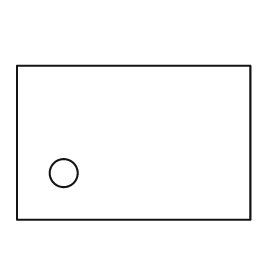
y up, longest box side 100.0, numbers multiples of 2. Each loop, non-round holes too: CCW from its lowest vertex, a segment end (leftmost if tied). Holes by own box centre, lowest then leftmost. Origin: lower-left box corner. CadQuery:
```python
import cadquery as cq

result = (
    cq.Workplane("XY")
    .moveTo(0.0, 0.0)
    .lineTo(100.0, 0.0)
    .lineTo(100.0, 66.0)
    .lineTo(0.0, 66.0)
    .close()
    .moveTo(20.0, 20.0)
    .circle(6.0)
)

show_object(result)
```